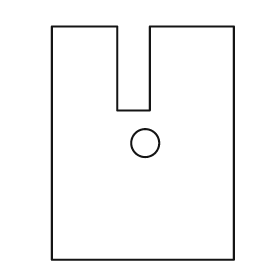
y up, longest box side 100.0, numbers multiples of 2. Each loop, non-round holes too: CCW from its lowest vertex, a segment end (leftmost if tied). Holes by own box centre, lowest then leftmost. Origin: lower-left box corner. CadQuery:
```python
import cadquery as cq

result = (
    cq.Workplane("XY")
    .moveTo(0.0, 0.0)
    .lineTo(78.0, 0.0)
    .lineTo(78.0, 100.0)
    .lineTo(42.0, 100.0)
    .lineTo(42.0, 64.0)
    .lineTo(28.0, 64.0)
    .lineTo(28.0, 100.0)
    .lineTo(0.0, 100.0)
    .close()
    .moveTo(40.0, 50.0)
    .circle(6.0)
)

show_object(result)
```